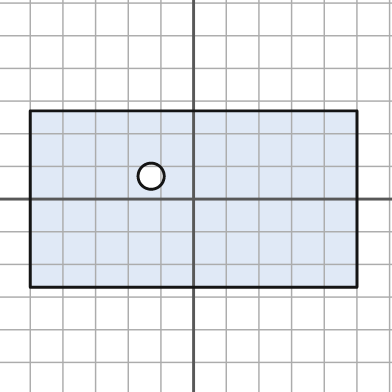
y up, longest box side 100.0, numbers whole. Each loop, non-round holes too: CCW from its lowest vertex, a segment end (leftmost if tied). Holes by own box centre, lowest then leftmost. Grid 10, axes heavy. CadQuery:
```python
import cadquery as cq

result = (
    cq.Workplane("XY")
    .moveTo(-50.0, -27.0)
    .lineTo(50.0, -27.0)
    .lineTo(50.0, 27.0)
    .lineTo(-50.0, 27.0)
    .close()
    .moveTo(-13.0, 7.0)
    .circle(4.0)
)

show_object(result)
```